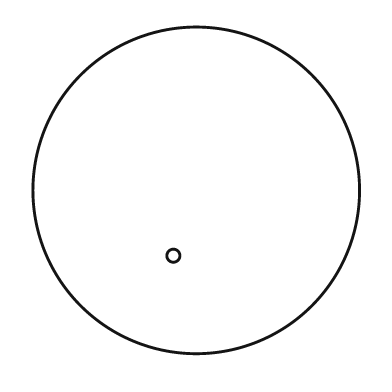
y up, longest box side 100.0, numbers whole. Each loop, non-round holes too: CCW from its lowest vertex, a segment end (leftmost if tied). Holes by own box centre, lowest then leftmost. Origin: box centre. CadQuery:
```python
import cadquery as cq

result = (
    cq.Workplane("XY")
    .moveTo(0.0, 0.0)
    .circle(50.0)
    .moveTo(-7.0, -20.0)
    .circle(2.0)
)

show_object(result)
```